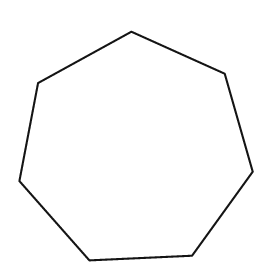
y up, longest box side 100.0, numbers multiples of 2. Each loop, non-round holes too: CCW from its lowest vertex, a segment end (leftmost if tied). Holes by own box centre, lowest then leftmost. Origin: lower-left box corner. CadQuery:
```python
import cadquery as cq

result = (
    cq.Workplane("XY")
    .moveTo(30.0, 0.0)
    .lineTo(74.0, 2.0)
    .lineTo(100.0, 38.0)
    .lineTo(88.0, 80.0)
    .lineTo(48.0, 98.0)
    .lineTo(8.0, 76.0)
    .lineTo(0.0, 34.0)
    .close()
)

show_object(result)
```